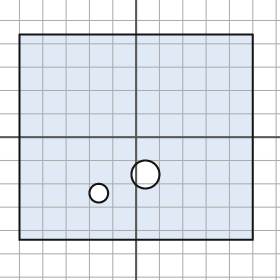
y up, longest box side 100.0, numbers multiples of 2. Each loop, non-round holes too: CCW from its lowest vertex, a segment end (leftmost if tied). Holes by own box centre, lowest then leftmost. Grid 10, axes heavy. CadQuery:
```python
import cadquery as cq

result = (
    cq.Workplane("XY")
    .moveTo(-50.0, -44.0)
    .lineTo(50.0, -44.0)
    .lineTo(50.0, 44.0)
    .lineTo(-50.0, 44.0)
    .close()
    .moveTo(-16.0, -24.0)
    .circle(4.0)
    .moveTo(4.0, -16.0)
    .circle(6.0)
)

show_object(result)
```